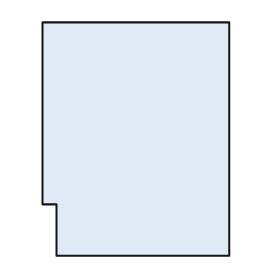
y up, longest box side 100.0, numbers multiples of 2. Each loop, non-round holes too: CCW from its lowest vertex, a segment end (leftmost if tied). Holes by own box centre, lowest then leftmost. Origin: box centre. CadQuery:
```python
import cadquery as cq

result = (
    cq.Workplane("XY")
    .moveTo(-34.0, -50.0)
    .lineTo(40.0, -50.0)
    .lineTo(40.0, 50.0)
    .lineTo(-40.0, 50.0)
    .lineTo(-40.0, -28.0)
    .lineTo(-34.0, -28.0)
    .close()
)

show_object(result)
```